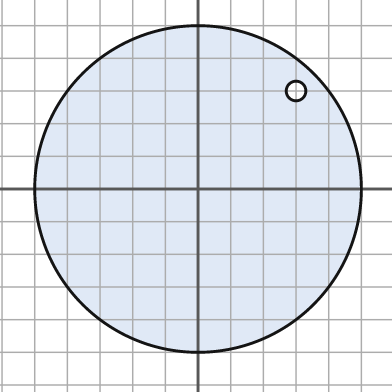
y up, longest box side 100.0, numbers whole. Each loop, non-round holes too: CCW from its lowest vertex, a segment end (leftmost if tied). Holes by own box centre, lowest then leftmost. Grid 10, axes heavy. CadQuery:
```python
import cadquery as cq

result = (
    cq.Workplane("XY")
    .moveTo(0.0, 0.0)
    .circle(50.0)
    .moveTo(30.0, 30.0)
    .circle(3.0)
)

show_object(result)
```